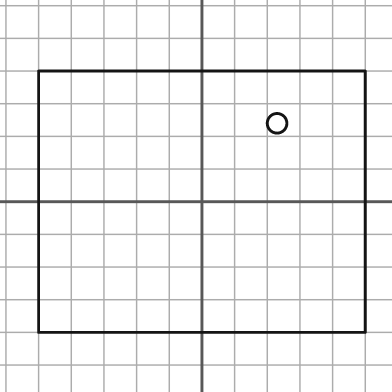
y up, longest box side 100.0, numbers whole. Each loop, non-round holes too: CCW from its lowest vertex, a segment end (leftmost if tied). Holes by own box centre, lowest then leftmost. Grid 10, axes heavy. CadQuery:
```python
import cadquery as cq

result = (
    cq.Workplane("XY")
    .moveTo(-50.0, -40.0)
    .lineTo(50.0, -40.0)
    .lineTo(50.0, 40.0)
    .lineTo(-50.0, 40.0)
    .close()
    .moveTo(23.0, 24.0)
    .circle(3.0)
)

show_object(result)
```